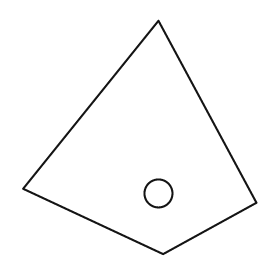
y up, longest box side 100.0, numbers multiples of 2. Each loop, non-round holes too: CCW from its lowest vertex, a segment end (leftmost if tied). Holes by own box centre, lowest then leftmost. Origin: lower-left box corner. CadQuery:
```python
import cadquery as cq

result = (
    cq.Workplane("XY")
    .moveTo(60.0, 0.0)
    .lineTo(100.0, 22.0)
    .lineTo(58.0, 100.0)
    .lineTo(0.0, 28.0)
    .close()
    .moveTo(58.0, 26.0)
    .circle(6.0)
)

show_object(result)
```